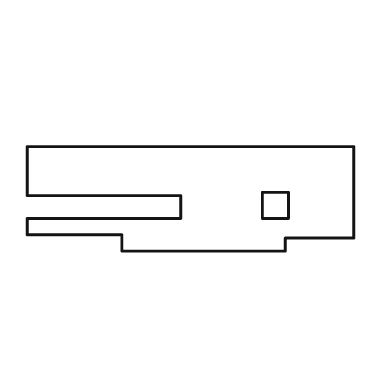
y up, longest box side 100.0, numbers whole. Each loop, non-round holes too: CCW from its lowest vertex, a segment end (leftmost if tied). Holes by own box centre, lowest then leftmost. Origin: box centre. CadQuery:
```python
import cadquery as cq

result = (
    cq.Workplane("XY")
    .moveTo(-21.0, -16.0)
    .lineTo(29.0, -16.0)
    .lineTo(29.0, -12.0)
    .lineTo(50.0, -12.0)
    .lineTo(50.0, 16.0)
    .lineTo(-50.0, 16.0)
    .lineTo(-50.0, 1.0)
    .lineTo(-3.0, 1.0)
    .lineTo(-3.0, -6.0)
    .lineTo(-50.0, -6.0)
    .lineTo(-50.0, -11.0)
    .lineTo(-21.0, -11.0)
    .close()
    .moveTo(22.0, -6.0)
    .lineTo(30.0, -6.0)
    .lineTo(30.0, 2.0)
    .lineTo(22.0, 2.0)
    .close()
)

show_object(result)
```